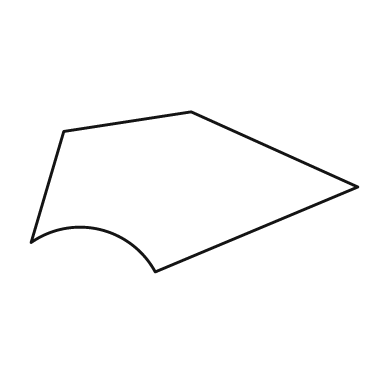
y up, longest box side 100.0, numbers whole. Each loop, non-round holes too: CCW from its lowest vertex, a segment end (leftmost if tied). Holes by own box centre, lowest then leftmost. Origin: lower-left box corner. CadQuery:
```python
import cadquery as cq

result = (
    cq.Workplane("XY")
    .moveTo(38.0, 0.0)
    .lineTo(100.0, 26.0)
    .lineTo(49.0, 49.0)
    .lineTo(10.0, 43.0)
    .lineTo(0.0, 9.0)
    .threePointArc((21.0, 13.0), (38.0, 0.0))
    .close()
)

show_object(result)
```